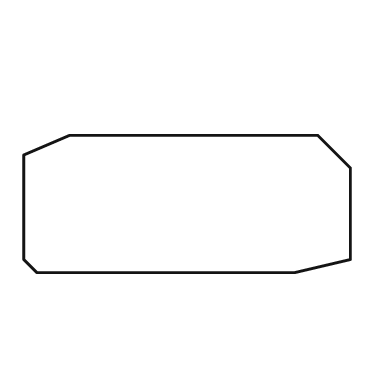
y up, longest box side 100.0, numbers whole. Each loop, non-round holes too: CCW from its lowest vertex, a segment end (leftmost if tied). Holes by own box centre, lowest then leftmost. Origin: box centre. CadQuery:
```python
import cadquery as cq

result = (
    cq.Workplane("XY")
    .moveTo(-46.0, -21.0)
    .lineTo(33.0, -21.0)
    .lineTo(50.0, -17.0)
    .lineTo(50.0, 11.0)
    .lineTo(40.0, 21.0)
    .lineTo(-36.0, 21.0)
    .lineTo(-50.0, 15.0)
    .lineTo(-50.0, -17.0)
    .close()
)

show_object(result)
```